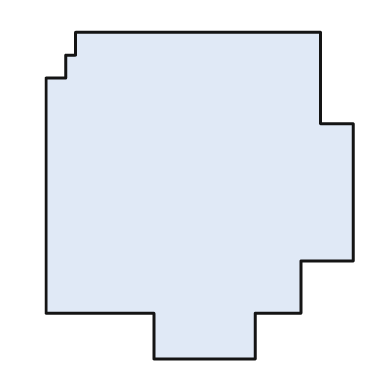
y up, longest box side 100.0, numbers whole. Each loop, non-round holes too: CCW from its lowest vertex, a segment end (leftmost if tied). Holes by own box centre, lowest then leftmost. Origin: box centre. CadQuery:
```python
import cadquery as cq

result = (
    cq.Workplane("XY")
    .moveTo(-14.0, -50.0)
    .lineTo(17.0, -50.0)
    .lineTo(17.0, -36.0)
    .lineTo(31.0, -36.0)
    .lineTo(31.0, -20.0)
    .lineTo(47.0, -20.0)
    .lineTo(47.0, 22.0)
    .lineTo(37.0, 22.0)
    .lineTo(37.0, 50.0)
    .lineTo(-38.0, 50.0)
    .lineTo(-38.0, 43.0)
    .lineTo(-41.0, 43.0)
    .lineTo(-41.0, 36.0)
    .lineTo(-47.0, 36.0)
    .lineTo(-47.0, -36.0)
    .lineTo(-14.0, -36.0)
    .close()
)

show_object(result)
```